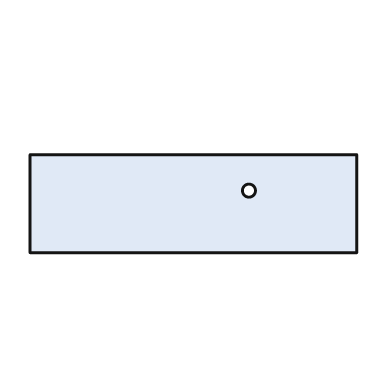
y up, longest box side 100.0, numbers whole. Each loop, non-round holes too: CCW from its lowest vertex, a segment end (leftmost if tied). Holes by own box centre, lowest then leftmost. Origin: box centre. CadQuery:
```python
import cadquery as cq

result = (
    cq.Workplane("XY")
    .moveTo(-50.0, -15.0)
    .lineTo(50.0, -15.0)
    .lineTo(50.0, 15.0)
    .lineTo(-50.0, 15.0)
    .close()
    .moveTo(17.0, 4.0)
    .circle(2.0)
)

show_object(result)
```